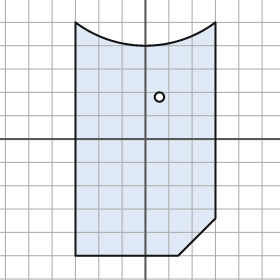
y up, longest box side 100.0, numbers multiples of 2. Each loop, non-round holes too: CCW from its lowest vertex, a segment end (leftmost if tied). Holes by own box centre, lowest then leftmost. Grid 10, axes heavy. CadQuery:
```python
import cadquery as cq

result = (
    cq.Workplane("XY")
    .moveTo(-30.0, -50.0)
    .lineTo(14.0, -50.0)
    .lineTo(30.0, -34.0)
    .lineTo(30.0, 50.0)
    .threePointArc((0.0, 40.0), (-30.0, 50.0))
    .close()
    .moveTo(6.0, 18.0)
    .circle(2.0)
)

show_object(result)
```